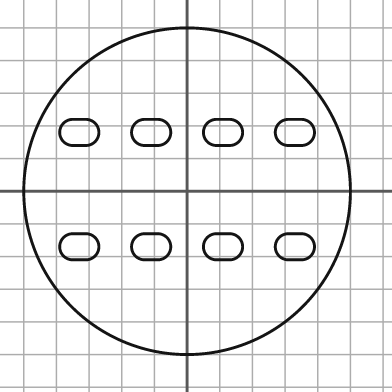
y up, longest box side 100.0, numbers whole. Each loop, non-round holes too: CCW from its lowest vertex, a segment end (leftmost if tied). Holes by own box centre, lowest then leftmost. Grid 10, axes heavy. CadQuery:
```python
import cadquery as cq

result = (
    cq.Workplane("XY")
    .moveTo(0.0, 0.0)
    .circle(50.0)
    .moveTo(-35.0, -21.0)
    .lineTo(-31.0, -21.0)
    .threePointArc((-27.0, -17.0), (-31.0, -13.0))
    .lineTo(-35.0, -13.0)
    .threePointArc((-39.0, -17.0), (-35.0, -21.0))
    .close()
    .moveTo(-13.0, -21.0)
    .lineTo(-9.0, -21.0)
    .threePointArc((-5.0, -17.0), (-9.0, -13.0))
    .lineTo(-13.0, -13.0)
    .threePointArc((-17.0, -17.0), (-13.0, -21.0))
    .close()
    .moveTo(9.0, -21.0)
    .lineTo(13.0, -21.0)
    .threePointArc((17.0, -17.0), (13.0, -13.0))
    .lineTo(9.0, -13.0)
    .threePointArc((5.0, -17.0), (9.0, -21.0))
    .close()
    .moveTo(31.0, -21.0)
    .lineTo(35.0, -21.0)
    .threePointArc((39.0, -17.0), (35.0, -13.0))
    .lineTo(31.0, -13.0)
    .threePointArc((27.0, -17.0), (31.0, -21.0))
    .close()
    .moveTo(-35.0, 14.0)
    .lineTo(-31.0, 14.0)
    .threePointArc((-27.0, 18.0), (-31.0, 22.0))
    .lineTo(-35.0, 22.0)
    .threePointArc((-39.0, 18.0), (-35.0, 14.0))
    .close()
    .moveTo(-13.0, 14.0)
    .lineTo(-9.0, 14.0)
    .threePointArc((-5.0, 18.0), (-9.0, 22.0))
    .lineTo(-13.0, 22.0)
    .threePointArc((-17.0, 18.0), (-13.0, 14.0))
    .close()
    .moveTo(9.0, 14.0)
    .lineTo(13.0, 14.0)
    .threePointArc((17.0, 18.0), (13.0, 22.0))
    .lineTo(9.0, 22.0)
    .threePointArc((5.0, 18.0), (9.0, 14.0))
    .close()
    .moveTo(31.0, 14.0)
    .lineTo(35.0, 14.0)
    .threePointArc((39.0, 18.0), (35.0, 22.0))
    .lineTo(31.0, 22.0)
    .threePointArc((27.0, 18.0), (31.0, 14.0))
    .close()
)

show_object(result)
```